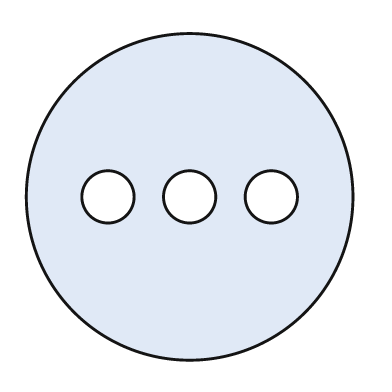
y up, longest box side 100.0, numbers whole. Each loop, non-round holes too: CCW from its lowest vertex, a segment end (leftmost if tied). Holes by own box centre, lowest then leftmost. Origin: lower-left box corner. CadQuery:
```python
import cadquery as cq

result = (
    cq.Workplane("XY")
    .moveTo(50.0, 50.0)
    .circle(50.0)
    .moveTo(25.0, 50.0)
    .circle(8.0)
    .moveTo(50.0, 50.0)
    .circle(8.0)
    .moveTo(75.0, 50.0)
    .circle(8.0)
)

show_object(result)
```